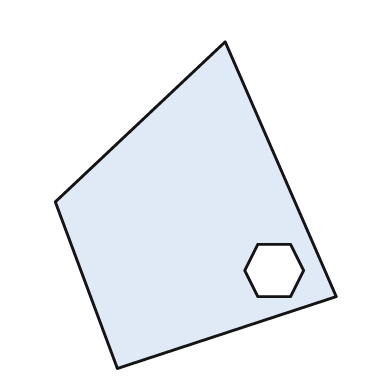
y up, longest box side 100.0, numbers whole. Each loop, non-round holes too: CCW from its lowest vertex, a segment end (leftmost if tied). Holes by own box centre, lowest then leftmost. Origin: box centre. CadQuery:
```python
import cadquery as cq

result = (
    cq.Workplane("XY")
    .moveTo(-24.0, -50.0)
    .lineTo(43.0, -28.0)
    .lineTo(9.0, 50.0)
    .lineTo(-43.0, 1.0)
    .close()
    .moveTo(19.0, -28.0)
    .lineTo(29.0, -28.0)
    .lineTo(33.0, -20.0)
    .lineTo(29.0, -12.0)
    .lineTo(19.0, -12.0)
    .lineTo(15.0, -20.0)
    .close()
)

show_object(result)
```